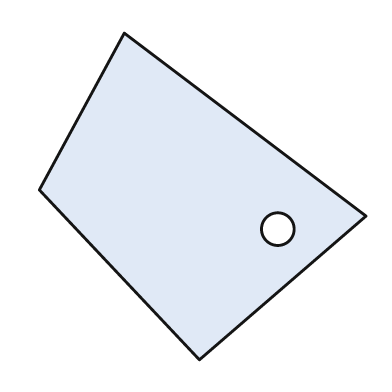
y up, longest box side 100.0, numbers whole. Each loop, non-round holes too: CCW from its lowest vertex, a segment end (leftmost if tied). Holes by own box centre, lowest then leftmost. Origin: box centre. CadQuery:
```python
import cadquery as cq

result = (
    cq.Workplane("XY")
    .moveTo(-1.0, -50.0)
    .lineTo(50.0, -6.0)
    .lineTo(-24.0, 50.0)
    .lineTo(-50.0, 2.0)
    .close()
    .moveTo(23.0, -10.0)
    .circle(5.0)
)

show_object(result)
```